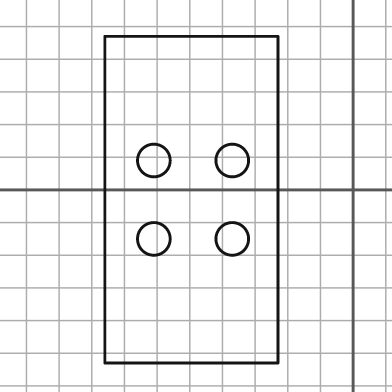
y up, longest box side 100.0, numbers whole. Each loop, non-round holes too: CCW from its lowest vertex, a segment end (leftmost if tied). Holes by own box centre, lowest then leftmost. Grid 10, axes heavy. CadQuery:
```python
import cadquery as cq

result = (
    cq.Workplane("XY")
    .moveTo(-76.0, -53.0)
    .lineTo(-23.0, -53.0)
    .lineTo(-23.0, 47.0)
    .lineTo(-76.0, 47.0)
    .close()
    .moveTo(-61.0, -15.0)
    .circle(5.0)
    .moveTo(-37.0, -15.0)
    .circle(5.0)
    .moveTo(-61.0, 9.0)
    .circle(5.0)
    .moveTo(-37.0, 9.0)
    .circle(5.0)
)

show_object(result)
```